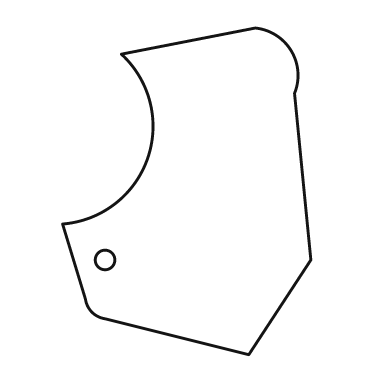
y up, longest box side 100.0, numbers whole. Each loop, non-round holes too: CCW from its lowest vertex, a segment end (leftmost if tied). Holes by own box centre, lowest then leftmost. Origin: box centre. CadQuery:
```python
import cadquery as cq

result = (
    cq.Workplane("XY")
    .moveTo(19.0, -50.0)
    .lineTo(38.0, -21.0)
    .lineTo(33.0, 30.0)
    .threePointArc((32.0, 43.0), (21.0, 50.0))
    .lineTo(-20.0, 42.0)
    .threePointArc((-12.0, 10.0), (-38.0, -10.0))
    .lineTo(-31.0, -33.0)
    .threePointArc((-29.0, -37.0), (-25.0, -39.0))
    .close()
    .moveTo(-25.0, -21.0)
    .circle(3.0)
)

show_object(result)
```